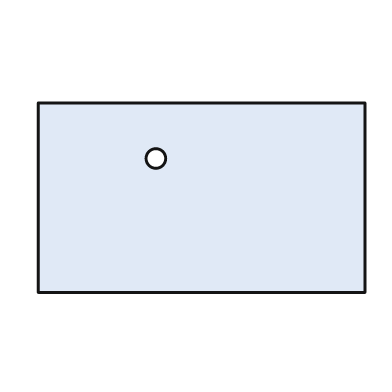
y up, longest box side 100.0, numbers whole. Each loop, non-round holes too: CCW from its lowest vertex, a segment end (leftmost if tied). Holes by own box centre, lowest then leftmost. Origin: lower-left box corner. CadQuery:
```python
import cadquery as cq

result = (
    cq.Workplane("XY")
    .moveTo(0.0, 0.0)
    .lineTo(100.0, 0.0)
    .lineTo(100.0, 58.0)
    .lineTo(0.0, 58.0)
    .close()
    .moveTo(36.0, 41.0)
    .circle(3.0)
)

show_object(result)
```